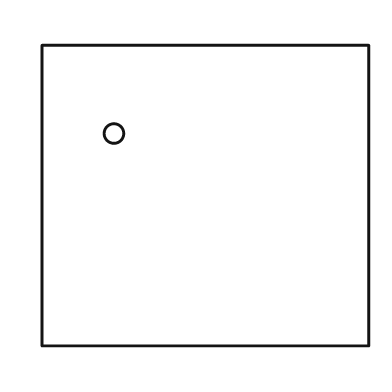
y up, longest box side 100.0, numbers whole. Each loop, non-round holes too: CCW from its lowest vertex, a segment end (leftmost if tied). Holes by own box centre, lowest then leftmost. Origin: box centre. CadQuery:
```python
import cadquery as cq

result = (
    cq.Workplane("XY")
    .moveTo(-50.0, -46.0)
    .lineTo(50.0, -46.0)
    .lineTo(50.0, 46.0)
    .lineTo(-50.0, 46.0)
    .close()
    .moveTo(-28.0, 19.0)
    .circle(3.0)
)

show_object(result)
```